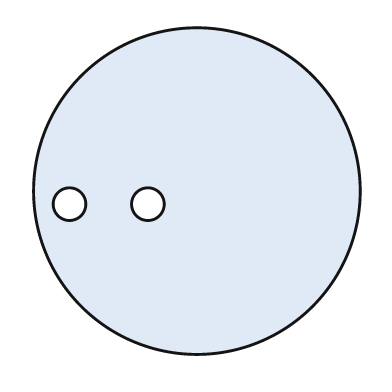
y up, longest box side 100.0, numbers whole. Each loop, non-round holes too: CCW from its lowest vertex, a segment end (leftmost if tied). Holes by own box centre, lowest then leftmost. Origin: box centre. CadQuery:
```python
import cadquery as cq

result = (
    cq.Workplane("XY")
    .moveTo(0.0, 0.0)
    .circle(50.0)
    .moveTo(-39.0, -4.0)
    .circle(5.0)
    .moveTo(-15.0, -4.0)
    .circle(5.0)
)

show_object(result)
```